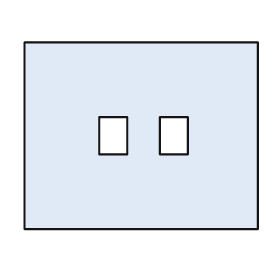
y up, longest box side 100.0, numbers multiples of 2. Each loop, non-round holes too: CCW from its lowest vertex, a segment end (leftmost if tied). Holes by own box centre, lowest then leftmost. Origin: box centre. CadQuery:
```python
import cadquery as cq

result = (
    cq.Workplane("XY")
    .moveTo(-50.0, -40.0)
    .lineTo(50.0, -40.0)
    .lineTo(50.0, 40.0)
    .lineTo(-50.0, 40.0)
    .close()
    .moveTo(-18.0, -8.0)
    .lineTo(-6.0, -8.0)
    .lineTo(-6.0, 8.0)
    .lineTo(-18.0, 8.0)
    .close()
    .moveTo(8.0, -8.0)
    .lineTo(20.0, -8.0)
    .lineTo(20.0, 8.0)
    .lineTo(8.0, 8.0)
    .close()
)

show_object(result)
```